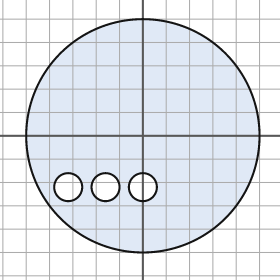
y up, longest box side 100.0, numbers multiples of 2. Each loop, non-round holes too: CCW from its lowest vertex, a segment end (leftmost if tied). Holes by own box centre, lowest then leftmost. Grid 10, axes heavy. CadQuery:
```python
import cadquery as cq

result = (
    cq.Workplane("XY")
    .moveTo(0.0, 0.0)
    .circle(50.0)
    .moveTo(-32.0, -22.0)
    .circle(6.0)
    .moveTo(-16.0, -22.0)
    .circle(6.0)
    .moveTo(0.0, -22.0)
    .circle(6.0)
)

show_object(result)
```